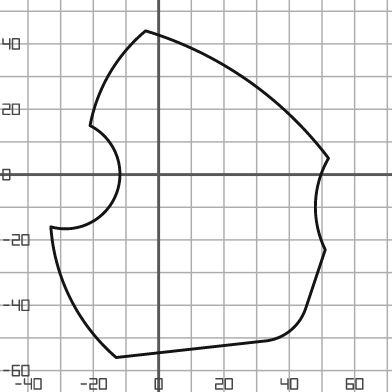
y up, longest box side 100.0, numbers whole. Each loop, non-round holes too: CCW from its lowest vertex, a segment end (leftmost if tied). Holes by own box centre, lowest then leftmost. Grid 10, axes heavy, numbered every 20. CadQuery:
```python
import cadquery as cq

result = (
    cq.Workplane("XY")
    .moveTo(-13.0, -56.0)
    .lineTo(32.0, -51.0)
    .threePointArc((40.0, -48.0), (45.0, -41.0))
    .lineTo(51.0, -23.0)
    .threePointArc((48.0, -9.0), (52.0, 5.0))
    .threePointArc((27.0, 29.0), (-4.0, 44.0))
    .threePointArc((-15.0, 31.0), (-21.0, 15.0))
    .threePointArc((-13.0, -6.0), (-33.0, -16.0))
    .threePointArc((-27.0, -38.0), (-13.0, -56.0))
    .close()
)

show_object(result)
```